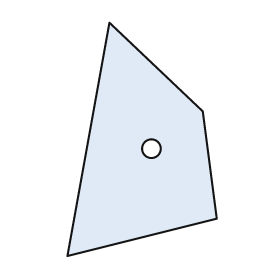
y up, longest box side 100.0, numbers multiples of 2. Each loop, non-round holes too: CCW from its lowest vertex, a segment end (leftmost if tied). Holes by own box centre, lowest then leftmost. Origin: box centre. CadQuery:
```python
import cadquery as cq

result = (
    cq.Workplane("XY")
    .moveTo(-32.0, -50.0)
    .lineTo(32.0, -34.0)
    .lineTo(26.0, 12.0)
    .lineTo(-14.0, 50.0)
    .close()
    .moveTo(4.0, -4.0)
    .circle(4.0)
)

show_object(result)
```